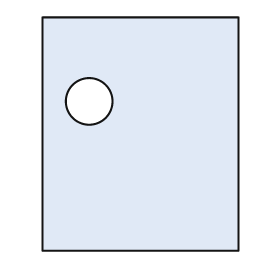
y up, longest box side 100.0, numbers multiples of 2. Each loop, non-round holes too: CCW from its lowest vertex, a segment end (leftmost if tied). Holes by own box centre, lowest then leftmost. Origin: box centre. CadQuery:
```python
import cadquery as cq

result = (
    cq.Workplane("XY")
    .moveTo(-42.0, -50.0)
    .lineTo(42.0, -50.0)
    .lineTo(42.0, 50.0)
    .lineTo(-42.0, 50.0)
    .close()
    .moveTo(-22.0, 14.0)
    .circle(10.0)
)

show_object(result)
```